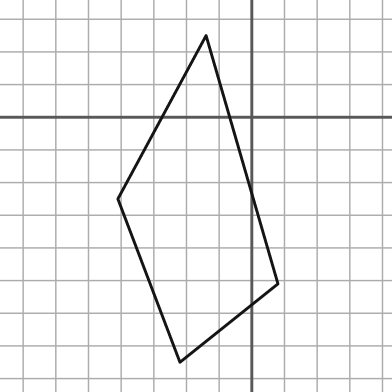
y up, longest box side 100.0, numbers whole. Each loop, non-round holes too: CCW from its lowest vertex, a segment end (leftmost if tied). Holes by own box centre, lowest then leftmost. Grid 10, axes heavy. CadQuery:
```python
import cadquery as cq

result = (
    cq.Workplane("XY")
    .moveTo(-22.0, -75.0)
    .lineTo(8.0, -51.0)
    .lineTo(-14.0, 25.0)
    .lineTo(-41.0, -25.0)
    .close()
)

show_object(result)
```